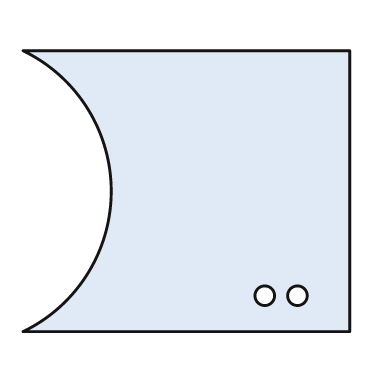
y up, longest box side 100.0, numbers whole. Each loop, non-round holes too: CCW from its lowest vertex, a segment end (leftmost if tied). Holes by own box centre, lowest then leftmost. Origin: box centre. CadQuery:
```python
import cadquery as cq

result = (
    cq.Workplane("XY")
    .moveTo(-50.0, -43.0)
    .lineTo(50.0, -43.0)
    .lineTo(50.0, 43.0)
    .lineTo(-50.0, 43.0)
    .threePointArc((-23.0, 0.0), (-50.0, -43.0))
    .close()
    .moveTo(24.0, -32.0)
    .circle(3.0)
    .moveTo(34.0, -32.0)
    .circle(3.0)
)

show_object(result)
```